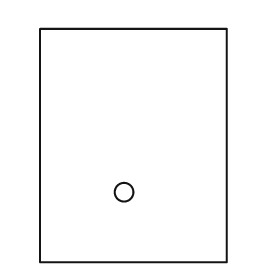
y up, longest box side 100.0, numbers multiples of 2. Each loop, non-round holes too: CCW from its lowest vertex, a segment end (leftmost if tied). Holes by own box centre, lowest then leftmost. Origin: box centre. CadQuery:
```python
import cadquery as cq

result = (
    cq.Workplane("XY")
    .moveTo(-40.0, -50.0)
    .lineTo(40.0, -50.0)
    .lineTo(40.0, 50.0)
    .lineTo(-40.0, 50.0)
    .close()
    .moveTo(-4.0, -20.0)
    .circle(4.0)
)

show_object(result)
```